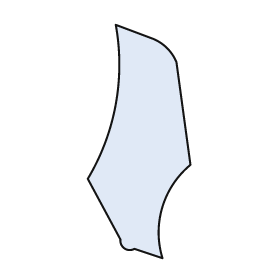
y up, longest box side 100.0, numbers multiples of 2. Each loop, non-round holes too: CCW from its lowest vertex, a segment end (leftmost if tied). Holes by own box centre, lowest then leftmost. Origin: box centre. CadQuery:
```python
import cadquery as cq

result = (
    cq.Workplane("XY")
    .moveTo(10.0, -50.0)
    .threePointArc((10.0, -28.0), (22.0, -10.0))
    .lineTo(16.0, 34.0)
    .threePointArc((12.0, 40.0), (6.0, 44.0))
    .lineTo(-10.0, 50.0)
    .threePointArc((-10.0, 16.0), (-22.0, -16.0))
    .lineTo(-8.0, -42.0)
    .threePointArc((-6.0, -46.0), (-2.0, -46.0))
    .close()
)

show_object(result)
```